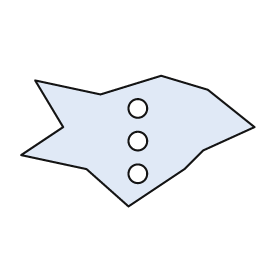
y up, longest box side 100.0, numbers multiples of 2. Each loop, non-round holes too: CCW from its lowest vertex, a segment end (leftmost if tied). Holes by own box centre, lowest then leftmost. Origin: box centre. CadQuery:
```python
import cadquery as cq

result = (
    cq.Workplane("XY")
    .moveTo(-4.0, -28.0)
    .lineTo(20.0, -12.0)
    .lineTo(28.0, -4.0)
    .lineTo(50.0, 6.0)
    .lineTo(30.0, 22.0)
    .lineTo(10.0, 28.0)
    .lineTo(-16.0, 20.0)
    .lineTo(-44.0, 26.0)
    .lineTo(-32.0, 6.0)
    .lineTo(-50.0, -6.0)
    .lineTo(-22.0, -12.0)
    .close()
    .moveTo(0.0, -14.0)
    .circle(4.0)
    .moveTo(0.0, 0.0)
    .circle(4.0)
    .moveTo(0.0, 14.0)
    .circle(4.0)
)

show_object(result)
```